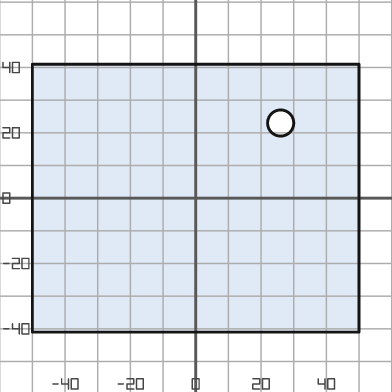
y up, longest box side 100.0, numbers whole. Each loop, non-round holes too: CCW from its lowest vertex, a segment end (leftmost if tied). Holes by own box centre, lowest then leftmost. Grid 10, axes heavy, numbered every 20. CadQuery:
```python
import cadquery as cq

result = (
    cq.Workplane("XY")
    .moveTo(-50.0, -41.0)
    .lineTo(50.0, -41.0)
    .lineTo(50.0, 41.0)
    .lineTo(-50.0, 41.0)
    .close()
    .moveTo(26.0, 23.0)
    .circle(4.0)
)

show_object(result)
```